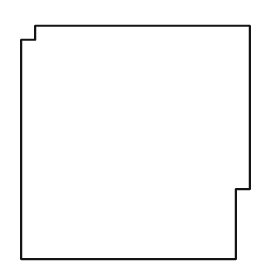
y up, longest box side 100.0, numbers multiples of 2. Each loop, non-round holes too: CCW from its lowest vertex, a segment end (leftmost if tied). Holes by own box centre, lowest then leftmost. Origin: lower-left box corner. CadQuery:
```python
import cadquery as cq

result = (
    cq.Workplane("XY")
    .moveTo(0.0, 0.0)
    .lineTo(92.0, 0.0)
    .lineTo(92.0, 30.0)
    .lineTo(98.0, 30.0)
    .lineTo(98.0, 100.0)
    .lineTo(6.0, 100.0)
    .lineTo(6.0, 94.0)
    .lineTo(0.0, 94.0)
    .close()
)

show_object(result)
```